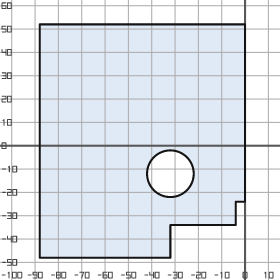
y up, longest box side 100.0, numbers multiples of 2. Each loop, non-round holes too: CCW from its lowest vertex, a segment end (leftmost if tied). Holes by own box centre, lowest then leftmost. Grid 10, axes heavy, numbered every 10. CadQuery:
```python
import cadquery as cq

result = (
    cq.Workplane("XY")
    .moveTo(-88.0, -48.0)
    .lineTo(-32.0, -48.0)
    .lineTo(-32.0, -34.0)
    .lineTo(-4.0, -34.0)
    .lineTo(-4.0, -24.0)
    .lineTo(0.0, -24.0)
    .lineTo(0.0, 52.0)
    .lineTo(-88.0, 52.0)
    .close()
    .moveTo(-32.0, -12.0)
    .circle(10.0)
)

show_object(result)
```